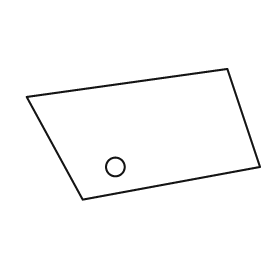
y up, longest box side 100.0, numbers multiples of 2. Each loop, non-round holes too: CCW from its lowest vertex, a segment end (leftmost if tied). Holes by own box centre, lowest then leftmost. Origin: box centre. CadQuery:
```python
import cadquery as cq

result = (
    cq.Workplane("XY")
    .moveTo(-26.0, -28.0)
    .lineTo(50.0, -14.0)
    .lineTo(36.0, 28.0)
    .lineTo(-50.0, 16.0)
    .close()
    .moveTo(-12.0, -14.0)
    .circle(4.0)
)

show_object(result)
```